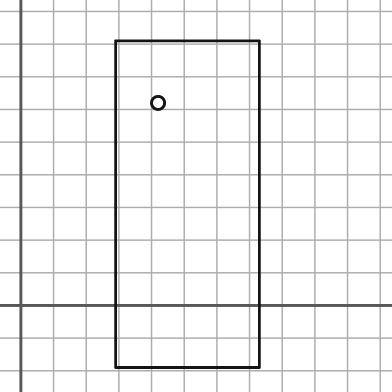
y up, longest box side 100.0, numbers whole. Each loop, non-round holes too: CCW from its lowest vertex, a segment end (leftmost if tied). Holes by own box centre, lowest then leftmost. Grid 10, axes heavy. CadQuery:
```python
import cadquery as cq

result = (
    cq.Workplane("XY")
    .moveTo(29.0, -19.0)
    .lineTo(73.0, -19.0)
    .lineTo(73.0, 81.0)
    .lineTo(29.0, 81.0)
    .close()
    .moveTo(42.0, 62.0)
    .circle(2.0)
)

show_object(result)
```